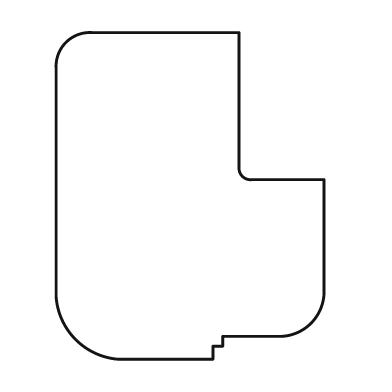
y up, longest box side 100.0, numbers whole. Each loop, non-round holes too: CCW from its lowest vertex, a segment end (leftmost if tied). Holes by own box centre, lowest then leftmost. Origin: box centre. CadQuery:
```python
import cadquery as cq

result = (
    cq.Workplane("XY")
    .moveTo(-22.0, -50.0)
    .lineTo(7.0, -50.0)
    .lineTo(7.0, -46.0)
    .lineTo(10.0, -46.0)
    .lineTo(10.0, -43.0)
    .lineTo(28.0, -43.0)
    .threePointArc((37.0, -39.0), (41.0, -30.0))
    .lineTo(41.0, 5.0)
    .lineTo(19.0, 5.0)
    .threePointArc((16.0, 6.0), (15.0, 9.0))
    .lineTo(15.0, 50.0)
    .lineTo(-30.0, 50.0)
    .threePointArc((-38.0, 47.0), (-41.0, 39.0))
    .lineTo(-41.0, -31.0)
    .threePointArc((-35.0, -44.0), (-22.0, -50.0))
    .close()
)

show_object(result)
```